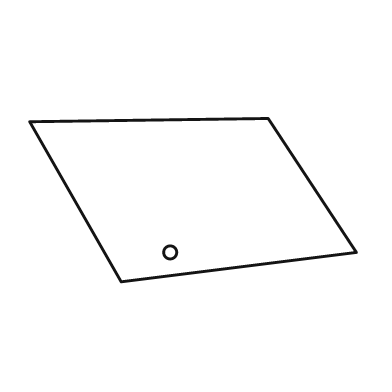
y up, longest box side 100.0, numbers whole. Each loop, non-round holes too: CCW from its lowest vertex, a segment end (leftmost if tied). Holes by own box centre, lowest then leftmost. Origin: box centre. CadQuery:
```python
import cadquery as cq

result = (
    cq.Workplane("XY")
    .moveTo(-22.0, -25.0)
    .lineTo(50.0, -16.0)
    .lineTo(23.0, 25.0)
    .lineTo(-50.0, 24.0)
    .close()
    .moveTo(-7.0, -16.0)
    .circle(2.0)
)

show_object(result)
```